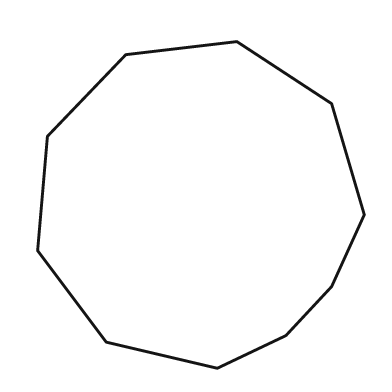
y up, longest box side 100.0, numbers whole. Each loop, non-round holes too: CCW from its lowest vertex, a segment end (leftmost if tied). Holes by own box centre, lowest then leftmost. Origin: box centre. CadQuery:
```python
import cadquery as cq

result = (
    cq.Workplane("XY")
    .moveTo(5.0, -50.0)
    .lineTo(26.0, -40.0)
    .lineTo(40.0, -25.0)
    .lineTo(50.0, -3.0)
    .lineTo(40.0, 31.0)
    .lineTo(11.0, 50.0)
    .lineTo(-23.0, 46.0)
    .lineTo(-47.0, 21.0)
    .lineTo(-50.0, -14.0)
    .lineTo(-29.0, -42.0)
    .close()
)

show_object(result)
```